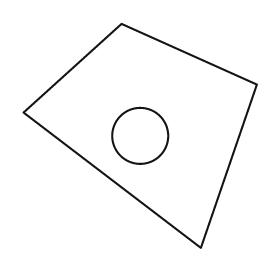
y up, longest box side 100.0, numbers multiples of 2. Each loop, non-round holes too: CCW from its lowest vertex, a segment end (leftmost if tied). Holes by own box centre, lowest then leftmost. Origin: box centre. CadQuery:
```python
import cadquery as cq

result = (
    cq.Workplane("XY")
    .moveTo(26.0, -48.0)
    .lineTo(50.0, 22.0)
    .lineTo(-8.0, 48.0)
    .lineTo(-50.0, 10.0)
    .close()
    .moveTo(0.0, 0.0)
    .circle(12.0)
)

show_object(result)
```